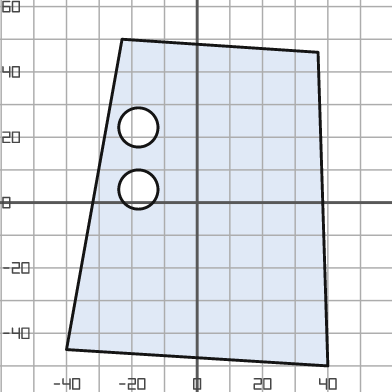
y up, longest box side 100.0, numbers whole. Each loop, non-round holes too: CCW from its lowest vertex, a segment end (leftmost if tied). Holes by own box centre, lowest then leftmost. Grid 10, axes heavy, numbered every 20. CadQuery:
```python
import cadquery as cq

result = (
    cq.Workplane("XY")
    .moveTo(40.0, -50.0)
    .lineTo(37.0, 46.0)
    .lineTo(-23.0, 50.0)
    .lineTo(-40.0, -45.0)
    .close()
    .moveTo(-18.0, 4.0)
    .circle(6.0)
    .moveTo(-18.0, 23.0)
    .circle(6.0)
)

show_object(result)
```